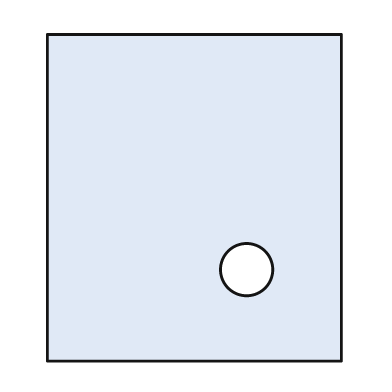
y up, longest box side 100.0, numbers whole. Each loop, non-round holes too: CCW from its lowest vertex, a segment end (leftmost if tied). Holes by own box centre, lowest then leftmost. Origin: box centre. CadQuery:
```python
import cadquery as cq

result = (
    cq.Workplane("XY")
    .moveTo(-45.0, -50.0)
    .lineTo(45.0, -50.0)
    .lineTo(45.0, 50.0)
    .lineTo(-45.0, 50.0)
    .close()
    .moveTo(16.0, -22.0)
    .circle(8.0)
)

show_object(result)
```